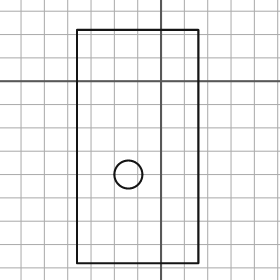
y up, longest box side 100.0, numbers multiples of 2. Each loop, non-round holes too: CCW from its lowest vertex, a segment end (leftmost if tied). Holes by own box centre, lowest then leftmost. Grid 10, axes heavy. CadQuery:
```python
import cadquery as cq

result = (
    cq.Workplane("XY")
    .moveTo(-36.0, -78.0)
    .lineTo(16.0, -78.0)
    .lineTo(16.0, 22.0)
    .lineTo(-36.0, 22.0)
    .close()
    .moveTo(-14.0, -40.0)
    .circle(6.0)
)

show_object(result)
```